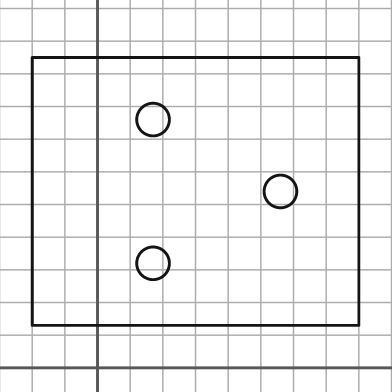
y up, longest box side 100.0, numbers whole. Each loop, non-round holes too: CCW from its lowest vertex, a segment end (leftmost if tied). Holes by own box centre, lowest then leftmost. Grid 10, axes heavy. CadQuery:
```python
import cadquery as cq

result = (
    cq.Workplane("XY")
    .moveTo(-20.0, 13.0)
    .lineTo(80.0, 13.0)
    .lineTo(80.0, 95.0)
    .lineTo(-20.0, 95.0)
    .close()
    .moveTo(17.0, 32.0)
    .circle(5.0)
    .moveTo(56.0, 54.0)
    .circle(5.0)
    .moveTo(17.0, 76.0)
    .circle(5.0)
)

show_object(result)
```